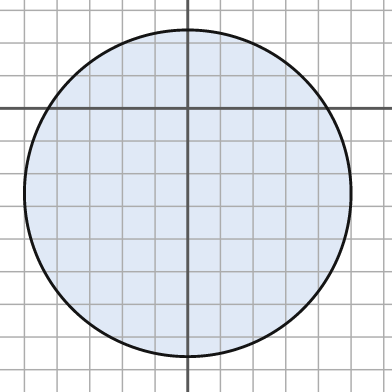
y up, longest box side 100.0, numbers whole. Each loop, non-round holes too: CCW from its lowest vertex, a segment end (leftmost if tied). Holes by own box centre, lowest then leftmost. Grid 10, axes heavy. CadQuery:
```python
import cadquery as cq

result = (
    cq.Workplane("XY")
    .moveTo(0.0, -26.0)
    .circle(50.0)
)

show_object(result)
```